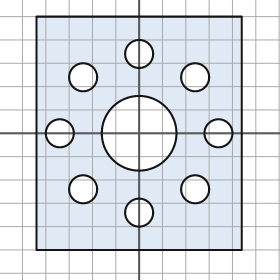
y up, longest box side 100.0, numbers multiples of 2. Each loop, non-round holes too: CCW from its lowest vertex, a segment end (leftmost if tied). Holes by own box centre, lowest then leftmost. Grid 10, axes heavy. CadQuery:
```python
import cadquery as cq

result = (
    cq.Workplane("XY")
    .moveTo(-44.0, -50.0)
    .lineTo(44.0, -50.0)
    .lineTo(44.0, 50.0)
    .lineTo(-44.0, 50.0)
    .close()
    .moveTo(0.0, -34.0)
    .circle(6.0)
    .moveTo(-24.0, -24.0)
    .circle(6.0)
    .moveTo(24.0, -24.0)
    .circle(6.0)
    .moveTo(-34.0, 0.0)
    .circle(6.0)
    .moveTo(0.0, 0.0)
    .circle(16.0)
    .moveTo(34.0, 0.0)
    .circle(6.0)
    .moveTo(-24.0, 24.0)
    .circle(6.0)
    .moveTo(24.0, 24.0)
    .circle(6.0)
    .moveTo(0.0, 34.0)
    .circle(6.0)
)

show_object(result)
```